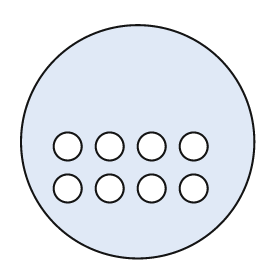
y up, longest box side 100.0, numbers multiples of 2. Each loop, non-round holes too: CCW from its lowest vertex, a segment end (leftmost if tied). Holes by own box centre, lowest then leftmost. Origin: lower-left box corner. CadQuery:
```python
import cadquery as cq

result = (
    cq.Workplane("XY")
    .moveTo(50.0, 50.0)
    .circle(50.0)
    .moveTo(20.0, 30.0)
    .circle(6.0)
    .moveTo(38.0, 30.0)
    .circle(6.0)
    .moveTo(56.0, 30.0)
    .circle(6.0)
    .moveTo(74.0, 30.0)
    .circle(6.0)
    .moveTo(20.0, 48.0)
    .circle(6.0)
    .moveTo(38.0, 48.0)
    .circle(6.0)
    .moveTo(56.0, 48.0)
    .circle(6.0)
    .moveTo(74.0, 48.0)
    .circle(6.0)
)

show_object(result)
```